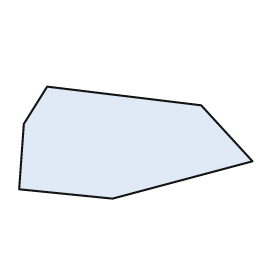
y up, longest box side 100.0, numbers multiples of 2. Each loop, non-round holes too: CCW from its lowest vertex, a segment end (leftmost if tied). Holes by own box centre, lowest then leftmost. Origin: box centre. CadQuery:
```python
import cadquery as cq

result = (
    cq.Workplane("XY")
    .moveTo(-10.0, -24.0)
    .lineTo(50.0, -8.0)
    .lineTo(28.0, 16.0)
    .lineTo(-38.0, 24.0)
    .lineTo(-48.0, 8.0)
    .lineTo(-50.0, -20.0)
    .close()
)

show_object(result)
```